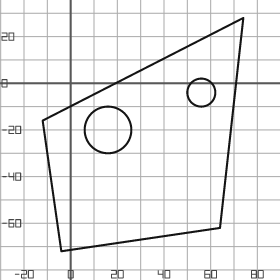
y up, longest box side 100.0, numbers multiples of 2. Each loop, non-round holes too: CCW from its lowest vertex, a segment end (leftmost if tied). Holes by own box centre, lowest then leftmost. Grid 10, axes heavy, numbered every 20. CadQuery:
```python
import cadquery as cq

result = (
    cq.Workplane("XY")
    .moveTo(-4.0, -72.0)
    .lineTo(64.0, -62.0)
    .lineTo(74.0, 28.0)
    .lineTo(-12.0, -16.0)
    .close()
    .moveTo(16.0, -20.0)
    .circle(10.0)
    .moveTo(56.0, -4.0)
    .circle(6.0)
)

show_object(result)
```